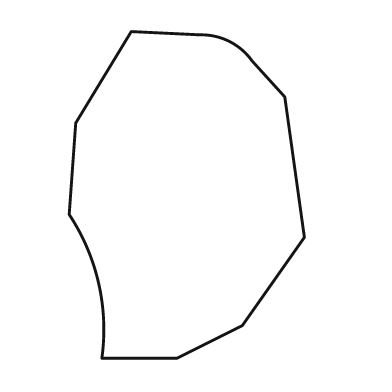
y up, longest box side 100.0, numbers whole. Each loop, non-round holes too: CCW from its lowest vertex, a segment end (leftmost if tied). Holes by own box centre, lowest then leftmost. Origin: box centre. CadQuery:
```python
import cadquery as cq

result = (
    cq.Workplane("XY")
    .moveTo(-26.0, -50.0)
    .lineTo(-3.0, -50.0)
    .lineTo(17.0, -40.0)
    .lineTo(36.0, -13.0)
    .lineTo(30.0, 30.0)
    .lineTo(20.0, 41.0)
    .threePointArc((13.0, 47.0), (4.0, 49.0))
    .lineTo(-17.0, 50.0)
    .lineTo(-34.0, 22.0)
    .lineTo(-36.0, -6.0)
    .threePointArc((-27.0, -27.0), (-26.0, -50.0))
    .close()
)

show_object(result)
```